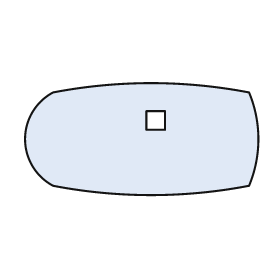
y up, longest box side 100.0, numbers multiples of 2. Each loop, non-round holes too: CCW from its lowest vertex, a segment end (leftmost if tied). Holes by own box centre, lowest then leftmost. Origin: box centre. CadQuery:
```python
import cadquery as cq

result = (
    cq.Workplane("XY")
    .moveTo(-38.0, -20.0)
    .threePointArc((4.0, -24.0), (46.0, -20.0))
    .threePointArc((50.0, 0.0), (46.0, 20.0))
    .threePointArc((4.0, 24.0), (-38.0, 20.0))
    .threePointArc((-50.0, 0.0), (-38.0, -20.0))
    .close()
    .moveTo(2.0, 4.0)
    .lineTo(10.0, 4.0)
    .lineTo(10.0, 12.0)
    .lineTo(2.0, 12.0)
    .close()
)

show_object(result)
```